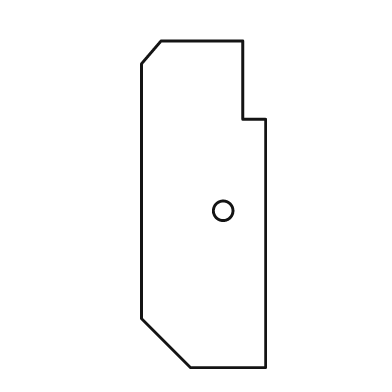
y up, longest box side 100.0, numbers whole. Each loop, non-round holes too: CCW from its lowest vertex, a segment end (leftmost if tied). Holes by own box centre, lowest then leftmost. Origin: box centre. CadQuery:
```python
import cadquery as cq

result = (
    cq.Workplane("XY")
    .moveTo(-4.0, -50.0)
    .lineTo(19.0, -50.0)
    .lineTo(19.0, 26.0)
    .lineTo(12.0, 26.0)
    .lineTo(12.0, 50.0)
    .lineTo(-13.0, 50.0)
    .lineTo(-19.0, 43.0)
    .lineTo(-19.0, -35.0)
    .close()
    .moveTo(6.0, -2.0)
    .circle(3.0)
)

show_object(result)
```